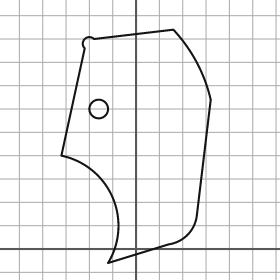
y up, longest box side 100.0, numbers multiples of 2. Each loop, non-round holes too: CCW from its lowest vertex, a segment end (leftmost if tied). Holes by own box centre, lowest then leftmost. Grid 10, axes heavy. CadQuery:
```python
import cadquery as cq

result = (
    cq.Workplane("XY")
    .moveTo(-12.0, -6.0)
    .lineTo(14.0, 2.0)
    .threePointArc((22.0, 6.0), (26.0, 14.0))
    .lineTo(32.0, 64.0)
    .threePointArc((26.0, 80.0), (16.0, 94.0))
    .lineTo(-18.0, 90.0)
    .threePointArc((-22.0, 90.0), (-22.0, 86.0))
    .lineTo(-32.0, 40.0)
    .threePointArc((-10.0, 22.0), (-12.0, -6.0))
    .close()
    .moveTo(-16.0, 60.0)
    .circle(4.0)
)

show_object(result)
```